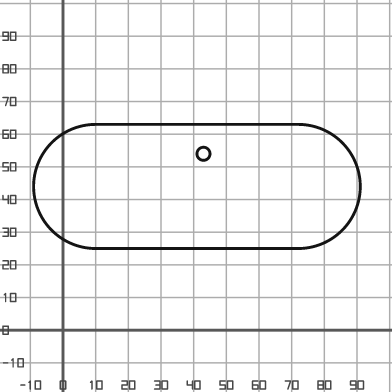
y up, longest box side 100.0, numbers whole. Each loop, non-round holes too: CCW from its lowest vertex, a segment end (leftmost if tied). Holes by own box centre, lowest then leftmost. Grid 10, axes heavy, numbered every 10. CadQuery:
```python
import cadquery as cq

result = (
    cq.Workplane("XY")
    .moveTo(10.0, 25.0)
    .lineTo(72.0, 25.0)
    .threePointArc((91.0, 44.0), (72.0, 63.0))
    .lineTo(10.0, 63.0)
    .threePointArc((-9.0, 44.0), (10.0, 25.0))
    .close()
    .moveTo(43.0, 54.0)
    .circle(2.0)
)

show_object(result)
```